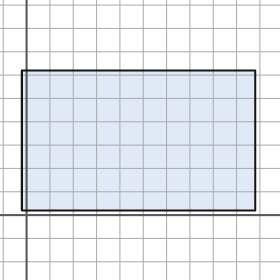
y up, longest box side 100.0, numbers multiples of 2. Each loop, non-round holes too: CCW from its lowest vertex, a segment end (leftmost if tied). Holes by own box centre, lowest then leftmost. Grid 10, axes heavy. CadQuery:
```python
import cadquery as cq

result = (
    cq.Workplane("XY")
    .moveTo(-2.0, 2.0)
    .lineTo(98.0, 2.0)
    .lineTo(98.0, 62.0)
    .lineTo(-2.0, 62.0)
    .close()
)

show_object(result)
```